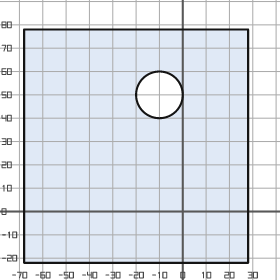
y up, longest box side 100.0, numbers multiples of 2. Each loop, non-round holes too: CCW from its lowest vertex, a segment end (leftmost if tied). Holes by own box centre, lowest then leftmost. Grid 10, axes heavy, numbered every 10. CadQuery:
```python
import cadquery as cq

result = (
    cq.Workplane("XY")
    .moveTo(-68.0, -22.0)
    .lineTo(28.0, -22.0)
    .lineTo(28.0, 78.0)
    .lineTo(-68.0, 78.0)
    .close()
    .moveTo(-10.0, 50.0)
    .circle(10.0)
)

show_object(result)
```